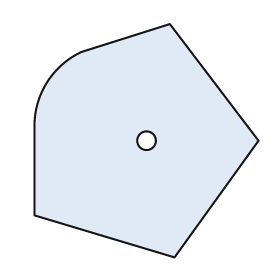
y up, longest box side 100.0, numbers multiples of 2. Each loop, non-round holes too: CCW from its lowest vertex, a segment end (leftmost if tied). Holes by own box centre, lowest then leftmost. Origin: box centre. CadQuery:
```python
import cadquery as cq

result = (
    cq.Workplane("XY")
    .moveTo(12.0, -50.0)
    .lineTo(48.0, 0.0)
    .lineTo(10.0, 50.0)
    .lineTo(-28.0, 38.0)
    .threePointArc((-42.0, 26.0), (-48.0, 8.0))
    .lineTo(-48.0, -32.0)
    .close()
    .moveTo(0.0, 0.0)
    .circle(4.0)
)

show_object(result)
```